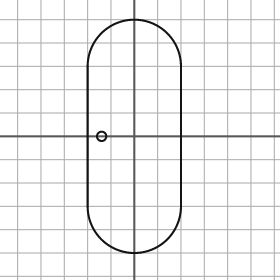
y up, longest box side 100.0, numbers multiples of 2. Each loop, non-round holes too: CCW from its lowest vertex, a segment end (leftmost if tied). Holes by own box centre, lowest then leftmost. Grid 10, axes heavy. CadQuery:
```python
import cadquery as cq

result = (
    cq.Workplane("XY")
    .moveTo(-20.0, -30.0)
    .threePointArc((0.0, -50.0), (20.0, -30.0))
    .lineTo(20.0, 30.0)
    .threePointArc((0.0, 50.0), (-20.0, 30.0))
    .close()
    .moveTo(-14.0, 0.0)
    .circle(2.0)
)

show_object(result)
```